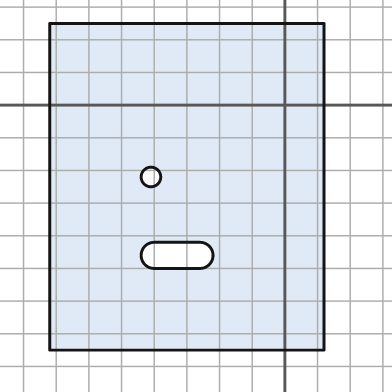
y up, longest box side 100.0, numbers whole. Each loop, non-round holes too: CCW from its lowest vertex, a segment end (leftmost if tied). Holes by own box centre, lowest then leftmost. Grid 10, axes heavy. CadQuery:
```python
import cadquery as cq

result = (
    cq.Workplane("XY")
    .moveTo(-72.0, -75.0)
    .lineTo(12.0, -75.0)
    .lineTo(12.0, 25.0)
    .lineTo(-72.0, 25.0)
    .close()
    .moveTo(-40.0, -50.0)
    .lineTo(-26.0, -50.0)
    .threePointArc((-22.0, -46.0), (-26.0, -42.0))
    .lineTo(-40.0, -42.0)
    .threePointArc((-44.0, -46.0), (-40.0, -50.0))
    .close()
    .moveTo(-41.0, -22.0)
    .circle(3.0)
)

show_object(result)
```